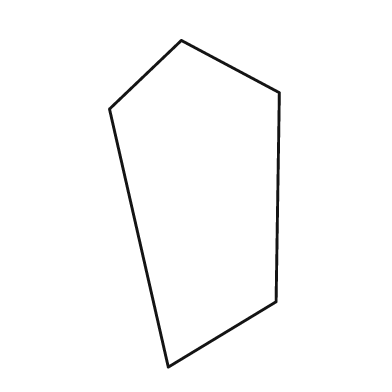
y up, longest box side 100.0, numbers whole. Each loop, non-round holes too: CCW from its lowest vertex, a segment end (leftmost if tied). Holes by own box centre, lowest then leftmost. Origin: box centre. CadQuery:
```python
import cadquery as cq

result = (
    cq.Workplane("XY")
    .moveTo(-8.0, -50.0)
    .lineTo(25.0, -30.0)
    .lineTo(26.0, 34.0)
    .lineTo(-4.0, 50.0)
    .lineTo(-26.0, 29.0)
    .close()
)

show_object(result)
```